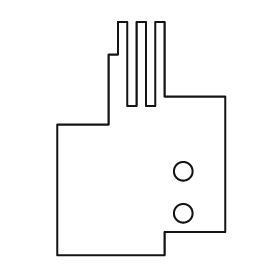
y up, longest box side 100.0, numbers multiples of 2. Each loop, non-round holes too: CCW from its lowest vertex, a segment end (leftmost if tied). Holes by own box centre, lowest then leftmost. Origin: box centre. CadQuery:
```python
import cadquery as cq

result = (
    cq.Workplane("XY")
    .moveTo(-36.0, -50.0)
    .lineTo(10.0, -50.0)
    .lineTo(10.0, -40.0)
    .lineTo(36.0, -40.0)
    .lineTo(36.0, 18.0)
    .lineTo(10.0, 18.0)
    .lineTo(10.0, 50.0)
    .lineTo(6.0, 50.0)
    .lineTo(6.0, 14.0)
    .lineTo(2.0, 14.0)
    .lineTo(2.0, 50.0)
    .lineTo(-2.0, 50.0)
    .lineTo(-2.0, 14.0)
    .lineTo(-6.0, 14.0)
    .lineTo(-6.0, 50.0)
    .lineTo(-10.0, 50.0)
    .lineTo(-10.0, 36.0)
    .lineTo(-14.0, 36.0)
    .lineTo(-14.0, 6.0)
    .lineTo(-36.0, 6.0)
    .close()
    .moveTo(18.0, -32.0)
    .circle(4.0)
    .moveTo(18.0, -14.0)
    .circle(4.0)
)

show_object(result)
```